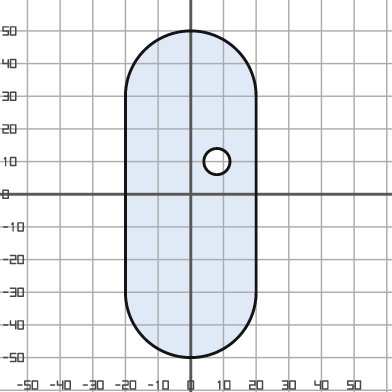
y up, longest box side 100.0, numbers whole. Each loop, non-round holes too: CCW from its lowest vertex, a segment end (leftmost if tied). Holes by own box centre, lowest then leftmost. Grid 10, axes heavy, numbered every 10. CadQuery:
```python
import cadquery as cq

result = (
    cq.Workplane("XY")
    .moveTo(-20.0, -30.0)
    .threePointArc((0.0, -50.0), (20.0, -30.0))
    .lineTo(20.0, 30.0)
    .threePointArc((0.0, 50.0), (-20.0, 30.0))
    .close()
    .moveTo(8.0, 10.0)
    .circle(4.0)
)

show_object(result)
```